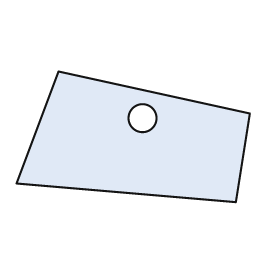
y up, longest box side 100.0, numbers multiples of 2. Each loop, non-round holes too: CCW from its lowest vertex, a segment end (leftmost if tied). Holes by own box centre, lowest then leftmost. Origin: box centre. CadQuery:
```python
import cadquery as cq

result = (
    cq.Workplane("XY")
    .moveTo(44.0, -28.0)
    .lineTo(50.0, 10.0)
    .lineTo(-32.0, 28.0)
    .lineTo(-50.0, -20.0)
    .close()
    .moveTo(4.0, 8.0)
    .circle(6.0)
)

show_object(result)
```